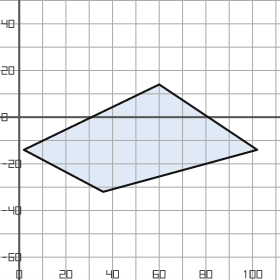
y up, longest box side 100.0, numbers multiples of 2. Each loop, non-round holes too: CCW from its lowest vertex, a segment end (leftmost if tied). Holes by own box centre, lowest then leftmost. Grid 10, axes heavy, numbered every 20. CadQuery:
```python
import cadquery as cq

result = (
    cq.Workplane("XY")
    .moveTo(36.0, -32.0)
    .lineTo(102.0, -14.0)
    .lineTo(60.0, 14.0)
    .lineTo(2.0, -14.0)
    .close()
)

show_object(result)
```